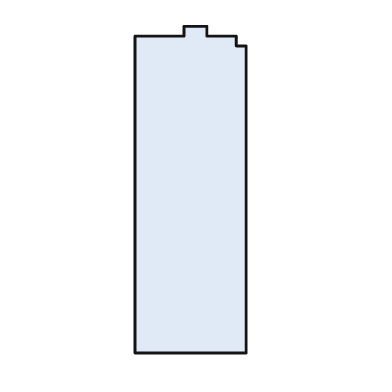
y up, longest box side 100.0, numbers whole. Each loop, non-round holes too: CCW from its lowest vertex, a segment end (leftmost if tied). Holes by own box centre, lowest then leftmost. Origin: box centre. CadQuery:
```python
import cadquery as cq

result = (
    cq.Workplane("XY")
    .moveTo(-17.0, -50.0)
    .lineTo(17.0, -50.0)
    .lineTo(17.0, 44.0)
    .lineTo(14.0, 44.0)
    .lineTo(14.0, 47.0)
    .lineTo(5.0, 47.0)
    .lineTo(5.0, 50.0)
    .lineTo(-2.0, 50.0)
    .lineTo(-2.0, 47.0)
    .lineTo(-17.0, 47.0)
    .close()
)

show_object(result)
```